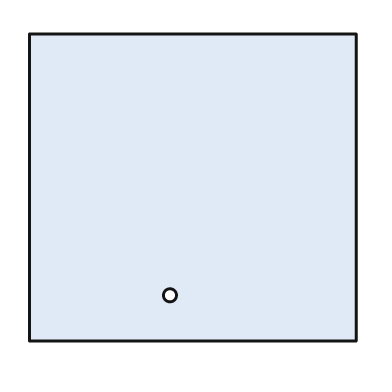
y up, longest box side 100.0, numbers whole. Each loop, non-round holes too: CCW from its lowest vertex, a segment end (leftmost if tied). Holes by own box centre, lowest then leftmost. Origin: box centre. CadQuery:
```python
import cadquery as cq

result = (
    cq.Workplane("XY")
    .moveTo(-50.0, -47.0)
    .lineTo(50.0, -47.0)
    .lineTo(50.0, 47.0)
    .lineTo(-50.0, 47.0)
    .close()
    .moveTo(-7.0, -33.0)
    .circle(2.0)
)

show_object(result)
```